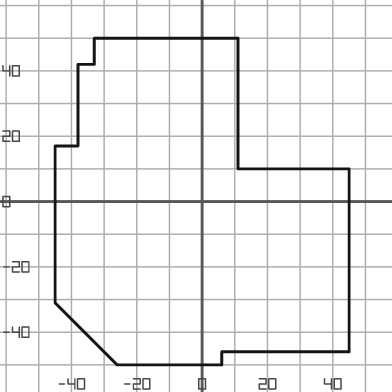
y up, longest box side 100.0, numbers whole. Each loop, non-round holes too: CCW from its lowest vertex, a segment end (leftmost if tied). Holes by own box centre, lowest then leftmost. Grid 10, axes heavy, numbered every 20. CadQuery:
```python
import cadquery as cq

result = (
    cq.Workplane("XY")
    .moveTo(-26.0, -50.0)
    .lineTo(6.0, -50.0)
    .lineTo(6.0, -46.0)
    .lineTo(45.0, -46.0)
    .lineTo(45.0, 10.0)
    .lineTo(11.0, 10.0)
    .lineTo(11.0, 50.0)
    .lineTo(-33.0, 50.0)
    .lineTo(-33.0, 42.0)
    .lineTo(-38.0, 42.0)
    .lineTo(-38.0, 17.0)
    .lineTo(-45.0, 17.0)
    .lineTo(-45.0, -31.0)
    .close()
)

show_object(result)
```